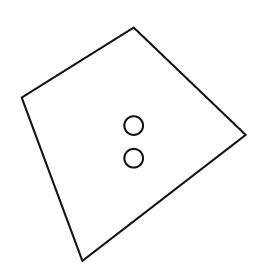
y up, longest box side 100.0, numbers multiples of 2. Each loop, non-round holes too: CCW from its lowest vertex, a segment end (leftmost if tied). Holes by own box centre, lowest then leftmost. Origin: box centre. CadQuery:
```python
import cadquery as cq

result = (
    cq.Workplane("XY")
    .moveTo(-22.0, -50.0)
    .lineTo(48.0, 4.0)
    .lineTo(0.0, 50.0)
    .lineTo(-48.0, 20.0)
    .close()
    .moveTo(0.0, -6.0)
    .circle(4.0)
    .moveTo(0.0, 8.0)
    .circle(4.0)
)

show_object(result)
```